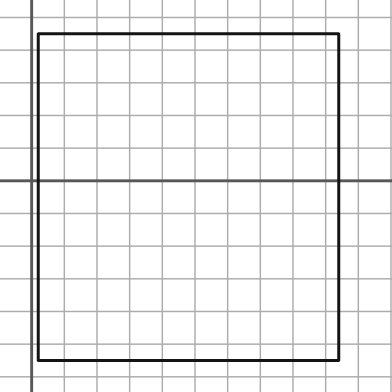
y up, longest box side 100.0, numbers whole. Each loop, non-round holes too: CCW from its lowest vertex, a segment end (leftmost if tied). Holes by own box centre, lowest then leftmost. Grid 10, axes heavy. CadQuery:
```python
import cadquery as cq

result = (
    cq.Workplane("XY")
    .moveTo(2.0, -55.0)
    .lineTo(94.0, -55.0)
    .lineTo(94.0, 45.0)
    .lineTo(2.0, 45.0)
    .close()
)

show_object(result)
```